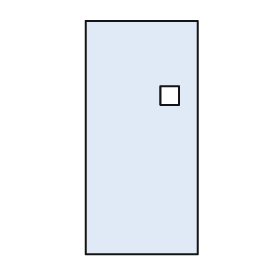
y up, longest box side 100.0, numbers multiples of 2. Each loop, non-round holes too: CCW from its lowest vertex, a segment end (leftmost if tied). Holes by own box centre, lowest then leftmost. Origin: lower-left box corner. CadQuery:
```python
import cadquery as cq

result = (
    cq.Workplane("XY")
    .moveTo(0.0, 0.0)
    .lineTo(48.0, 0.0)
    .lineTo(48.0, 100.0)
    .lineTo(0.0, 100.0)
    .close()
    .moveTo(32.0, 64.0)
    .lineTo(40.0, 64.0)
    .lineTo(40.0, 72.0)
    .lineTo(32.0, 72.0)
    .close()
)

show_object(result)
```